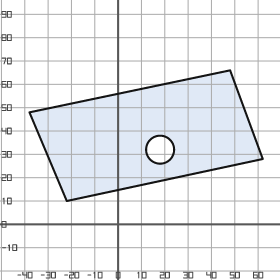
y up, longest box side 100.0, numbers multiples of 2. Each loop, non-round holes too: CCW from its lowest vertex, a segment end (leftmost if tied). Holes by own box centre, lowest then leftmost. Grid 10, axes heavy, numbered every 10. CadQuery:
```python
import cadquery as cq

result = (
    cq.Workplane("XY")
    .moveTo(-22.0, 10.0)
    .lineTo(62.0, 28.0)
    .lineTo(48.0, 66.0)
    .lineTo(-38.0, 48.0)
    .close()
    .moveTo(18.0, 32.0)
    .circle(6.0)
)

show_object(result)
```